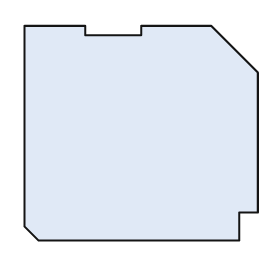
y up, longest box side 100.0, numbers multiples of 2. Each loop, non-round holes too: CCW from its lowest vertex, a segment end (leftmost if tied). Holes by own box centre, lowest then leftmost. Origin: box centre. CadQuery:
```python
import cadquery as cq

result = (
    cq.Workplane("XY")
    .moveTo(-44.0, -46.0)
    .lineTo(42.0, -46.0)
    .lineTo(42.0, -34.0)
    .lineTo(50.0, -34.0)
    .lineTo(50.0, 26.0)
    .lineTo(30.0, 46.0)
    .lineTo(0.0, 46.0)
    .lineTo(0.0, 42.0)
    .lineTo(-24.0, 42.0)
    .lineTo(-24.0, 46.0)
    .lineTo(-50.0, 46.0)
    .lineTo(-50.0, -40.0)
    .close()
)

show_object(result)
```